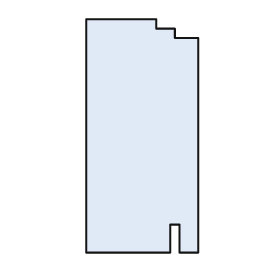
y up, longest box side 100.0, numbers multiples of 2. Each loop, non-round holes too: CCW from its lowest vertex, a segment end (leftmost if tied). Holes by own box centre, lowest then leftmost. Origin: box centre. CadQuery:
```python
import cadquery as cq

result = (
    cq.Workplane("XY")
    .moveTo(-24.0, -50.0)
    .lineTo(12.0, -50.0)
    .lineTo(12.0, -38.0)
    .lineTo(16.0, -38.0)
    .lineTo(16.0, -50.0)
    .lineTo(24.0, -50.0)
    .lineTo(24.0, 42.0)
    .lineTo(14.0, 42.0)
    .lineTo(14.0, 46.0)
    .lineTo(6.0, 46.0)
    .lineTo(6.0, 50.0)
    .lineTo(-24.0, 50.0)
    .close()
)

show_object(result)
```